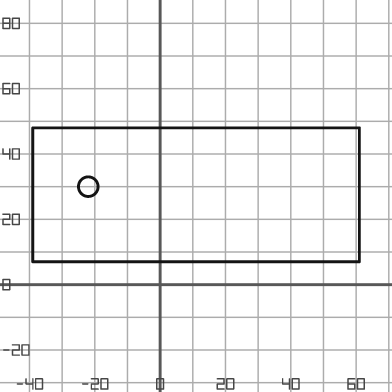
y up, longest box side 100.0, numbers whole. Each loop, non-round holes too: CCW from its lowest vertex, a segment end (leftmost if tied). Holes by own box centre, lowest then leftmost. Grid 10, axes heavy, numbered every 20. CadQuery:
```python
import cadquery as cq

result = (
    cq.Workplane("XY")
    .moveTo(-39.0, 7.0)
    .lineTo(61.0, 7.0)
    .lineTo(61.0, 48.0)
    .lineTo(-39.0, 48.0)
    .close()
    .moveTo(-22.0, 30.0)
    .circle(3.0)
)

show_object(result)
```